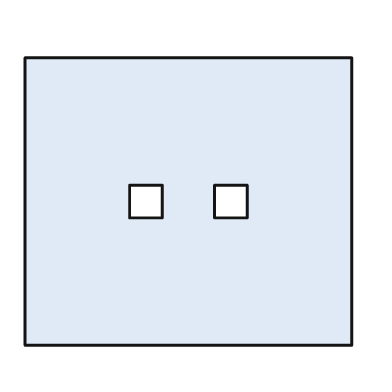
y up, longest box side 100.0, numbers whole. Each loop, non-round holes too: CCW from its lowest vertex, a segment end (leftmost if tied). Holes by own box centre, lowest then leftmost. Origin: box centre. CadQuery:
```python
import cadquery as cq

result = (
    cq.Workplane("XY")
    .moveTo(-50.0, -44.0)
    .lineTo(50.0, -44.0)
    .lineTo(50.0, 44.0)
    .lineTo(-50.0, 44.0)
    .close()
    .moveTo(-18.0, -5.0)
    .lineTo(-8.0, -5.0)
    .lineTo(-8.0, 5.0)
    .lineTo(-18.0, 5.0)
    .close()
    .moveTo(8.0, -5.0)
    .lineTo(18.0, -5.0)
    .lineTo(18.0, 5.0)
    .lineTo(8.0, 5.0)
    .close()
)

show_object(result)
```